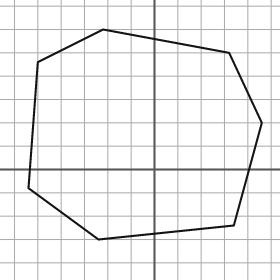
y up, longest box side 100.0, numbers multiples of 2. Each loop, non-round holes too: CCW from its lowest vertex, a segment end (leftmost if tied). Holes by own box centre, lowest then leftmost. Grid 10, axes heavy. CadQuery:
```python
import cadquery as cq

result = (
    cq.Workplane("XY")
    .moveTo(-24.0, -30.0)
    .lineTo(34.0, -24.0)
    .lineTo(46.0, 20.0)
    .lineTo(32.0, 50.0)
    .lineTo(-22.0, 60.0)
    .lineTo(-50.0, 46.0)
    .lineTo(-54.0, -8.0)
    .close()
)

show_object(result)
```